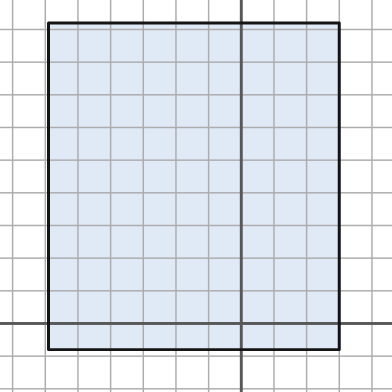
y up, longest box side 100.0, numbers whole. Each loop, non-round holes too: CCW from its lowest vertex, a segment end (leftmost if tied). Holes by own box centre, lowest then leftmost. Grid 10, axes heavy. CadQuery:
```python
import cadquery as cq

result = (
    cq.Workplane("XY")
    .moveTo(-59.0, -8.0)
    .lineTo(30.0, -8.0)
    .lineTo(30.0, 92.0)
    .lineTo(-59.0, 92.0)
    .close()
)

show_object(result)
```